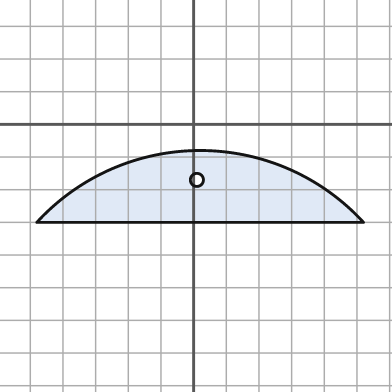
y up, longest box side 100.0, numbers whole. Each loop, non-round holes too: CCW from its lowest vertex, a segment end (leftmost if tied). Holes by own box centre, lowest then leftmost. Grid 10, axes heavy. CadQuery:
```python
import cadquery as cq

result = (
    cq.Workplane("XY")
    .moveTo(-48.0, -30.0)
    .lineTo(52.0, -30.0)
    .threePointArc((2.0, -8.0), (-48.0, -30.0))
    .close()
    .moveTo(1.0, -17.0)
    .circle(2.0)
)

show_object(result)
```